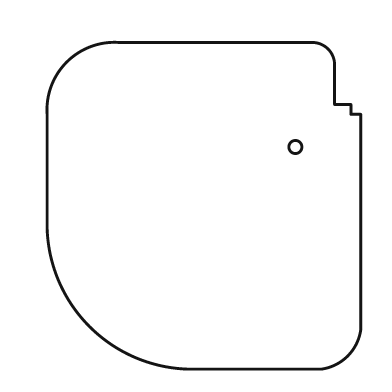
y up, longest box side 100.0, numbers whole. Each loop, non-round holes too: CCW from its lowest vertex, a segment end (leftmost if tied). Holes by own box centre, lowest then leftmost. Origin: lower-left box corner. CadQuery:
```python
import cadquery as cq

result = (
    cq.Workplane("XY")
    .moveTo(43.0, 0.0)
    .lineTo(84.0, 0.0)
    .threePointArc((92.0, 4.0), (96.0, 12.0))
    .lineTo(96.0, 78.0)
    .lineTo(93.0, 78.0)
    .lineTo(93.0, 81.0)
    .lineTo(88.0, 81.0)
    .lineTo(88.0, 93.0)
    .threePointArc((86.0, 98.0), (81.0, 100.0))
    .lineTo(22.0, 100.0)
    .threePointArc((6.0, 94.0), (0.0, 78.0))
    .lineTo(0.0, 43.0)
    .threePointArc((13.0, 13.0), (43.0, 0.0))
    .close()
    .moveTo(76.0, 68.0)
    .circle(2.0)
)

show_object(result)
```